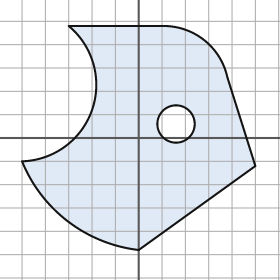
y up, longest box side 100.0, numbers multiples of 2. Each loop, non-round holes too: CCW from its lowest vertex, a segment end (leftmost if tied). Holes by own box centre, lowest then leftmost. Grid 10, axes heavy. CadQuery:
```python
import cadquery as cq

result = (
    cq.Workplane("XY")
    .moveTo(0.0, -48.0)
    .lineTo(50.0, -12.0)
    .lineTo(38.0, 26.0)
    .threePointArc((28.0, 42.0), (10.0, 48.0))
    .lineTo(-30.0, 48.0)
    .threePointArc((-20.0, 12.0), (-50.0, -10.0))
    .threePointArc((-30.0, -36.0), (0.0, -48.0))
    .close()
    .moveTo(16.0, 6.0)
    .circle(8.0)
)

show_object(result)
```